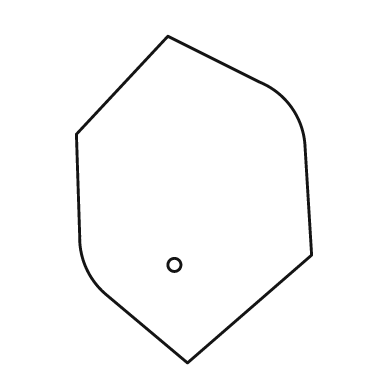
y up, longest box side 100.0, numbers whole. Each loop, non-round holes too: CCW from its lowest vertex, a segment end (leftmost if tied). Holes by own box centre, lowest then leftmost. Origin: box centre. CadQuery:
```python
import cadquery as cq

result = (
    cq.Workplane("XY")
    .moveTo(-2.0, -50.0)
    .lineTo(36.0, -17.0)
    .lineTo(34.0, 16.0)
    .threePointArc((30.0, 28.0), (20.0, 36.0))
    .lineTo(-8.0, 50.0)
    .lineTo(-36.0, 20.0)
    .lineTo(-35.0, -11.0)
    .threePointArc((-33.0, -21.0), (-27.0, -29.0))
    .close()
    .moveTo(-6.0, -20.0)
    .circle(2.0)
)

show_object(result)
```